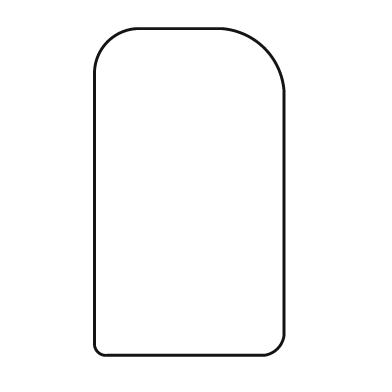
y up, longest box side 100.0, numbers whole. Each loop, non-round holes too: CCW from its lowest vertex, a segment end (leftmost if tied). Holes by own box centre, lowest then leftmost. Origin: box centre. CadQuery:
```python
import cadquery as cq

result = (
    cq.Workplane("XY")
    .moveTo(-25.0, -50.0)
    .lineTo(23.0, -50.0)
    .threePointArc((27.0, -48.0), (29.0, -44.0))
    .lineTo(29.0, 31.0)
    .threePointArc((23.0, 44.0), (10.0, 50.0))
    .lineTo(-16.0, 50.0)
    .threePointArc((-25.0, 46.0), (-29.0, 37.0))
    .lineTo(-29.0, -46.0)
    .threePointArc((-28.0, -49.0), (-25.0, -50.0))
    .close()
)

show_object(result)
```